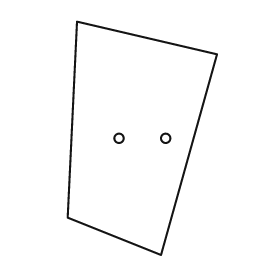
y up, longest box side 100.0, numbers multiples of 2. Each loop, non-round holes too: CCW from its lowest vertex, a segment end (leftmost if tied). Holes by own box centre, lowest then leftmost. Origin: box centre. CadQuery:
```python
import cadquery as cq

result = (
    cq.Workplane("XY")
    .moveTo(8.0, -50.0)
    .lineTo(32.0, 36.0)
    .lineTo(-28.0, 50.0)
    .lineTo(-32.0, -34.0)
    .close()
    .moveTo(-10.0, 0.0)
    .circle(2.0)
    .moveTo(10.0, 0.0)
    .circle(2.0)
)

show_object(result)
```